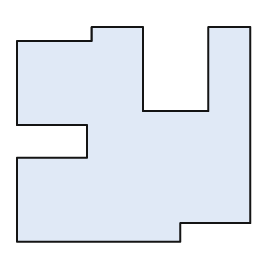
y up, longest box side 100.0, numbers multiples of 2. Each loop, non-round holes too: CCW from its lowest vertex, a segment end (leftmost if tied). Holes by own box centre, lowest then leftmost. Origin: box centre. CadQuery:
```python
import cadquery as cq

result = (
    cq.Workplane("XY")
    .moveTo(-50.0, -46.0)
    .lineTo(20.0, -46.0)
    .lineTo(20.0, -38.0)
    .lineTo(50.0, -38.0)
    .lineTo(50.0, 46.0)
    .lineTo(32.0, 46.0)
    .lineTo(32.0, 10.0)
    .lineTo(4.0, 10.0)
    .lineTo(4.0, 46.0)
    .lineTo(-18.0, 46.0)
    .lineTo(-18.0, 40.0)
    .lineTo(-50.0, 40.0)
    .lineTo(-50.0, 4.0)
    .lineTo(-20.0, 4.0)
    .lineTo(-20.0, -10.0)
    .lineTo(-50.0, -10.0)
    .close()
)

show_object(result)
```